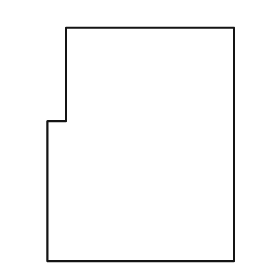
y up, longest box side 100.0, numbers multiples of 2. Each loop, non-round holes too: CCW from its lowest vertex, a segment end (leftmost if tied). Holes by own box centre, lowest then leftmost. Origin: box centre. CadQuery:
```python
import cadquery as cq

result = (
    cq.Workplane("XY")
    .moveTo(-40.0, -50.0)
    .lineTo(40.0, -50.0)
    .lineTo(40.0, 50.0)
    .lineTo(-32.0, 50.0)
    .lineTo(-32.0, 10.0)
    .lineTo(-40.0, 10.0)
    .close()
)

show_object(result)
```